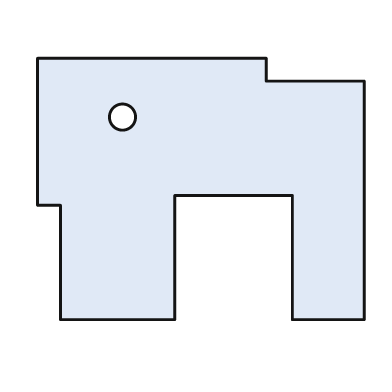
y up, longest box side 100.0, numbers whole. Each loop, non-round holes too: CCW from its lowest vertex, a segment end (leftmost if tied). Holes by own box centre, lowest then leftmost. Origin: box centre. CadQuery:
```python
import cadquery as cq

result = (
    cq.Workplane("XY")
    .moveTo(-43.0, -40.0)
    .lineTo(-8.0, -40.0)
    .lineTo(-8.0, -2.0)
    .lineTo(28.0, -2.0)
    .lineTo(28.0, -40.0)
    .lineTo(50.0, -40.0)
    .lineTo(50.0, 33.0)
    .lineTo(20.0, 33.0)
    .lineTo(20.0, 40.0)
    .lineTo(-50.0, 40.0)
    .lineTo(-50.0, -5.0)
    .lineTo(-43.0, -5.0)
    .close()
    .moveTo(-24.0, 22.0)
    .circle(4.0)
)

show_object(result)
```